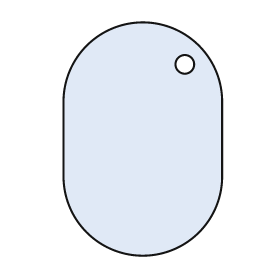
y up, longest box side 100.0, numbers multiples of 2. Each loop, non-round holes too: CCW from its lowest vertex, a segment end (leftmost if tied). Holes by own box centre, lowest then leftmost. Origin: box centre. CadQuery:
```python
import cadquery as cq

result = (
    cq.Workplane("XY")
    .moveTo(-34.0, -16.0)
    .threePointArc((0.0, -50.0), (34.0, -16.0))
    .lineTo(34.0, 16.0)
    .threePointArc((0.0, 50.0), (-34.0, 16.0))
    .close()
    .moveTo(18.0, 32.0)
    .circle(4.0)
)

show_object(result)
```